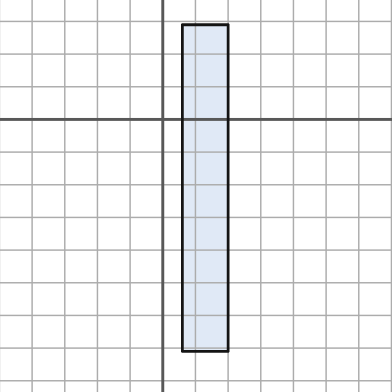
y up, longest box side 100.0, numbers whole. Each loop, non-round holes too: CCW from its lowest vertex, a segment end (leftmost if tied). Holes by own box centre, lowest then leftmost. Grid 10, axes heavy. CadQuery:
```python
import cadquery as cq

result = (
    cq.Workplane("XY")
    .moveTo(6.0, -71.0)
    .lineTo(20.0, -71.0)
    .lineTo(20.0, 29.0)
    .lineTo(6.0, 29.0)
    .close()
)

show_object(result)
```